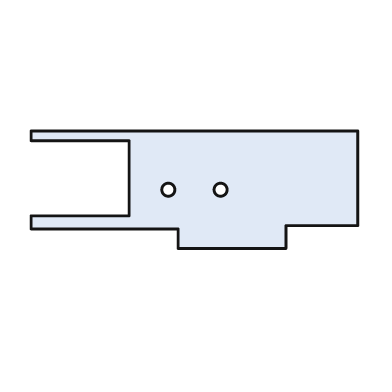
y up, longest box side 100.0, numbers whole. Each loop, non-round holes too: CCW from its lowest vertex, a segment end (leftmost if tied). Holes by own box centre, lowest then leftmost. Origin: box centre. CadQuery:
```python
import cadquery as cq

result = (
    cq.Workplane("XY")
    .moveTo(-5.0, -18.0)
    .lineTo(28.0, -18.0)
    .lineTo(28.0, -11.0)
    .lineTo(50.0, -11.0)
    .lineTo(50.0, 18.0)
    .lineTo(-50.0, 18.0)
    .lineTo(-50.0, 15.0)
    .lineTo(-20.0, 15.0)
    .lineTo(-20.0, -8.0)
    .lineTo(-50.0, -8.0)
    .lineTo(-50.0, -12.0)
    .lineTo(-5.0, -12.0)
    .close()
    .moveTo(-8.0, 0.0)
    .circle(2.0)
    .moveTo(8.0, 0.0)
    .circle(2.0)
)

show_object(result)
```